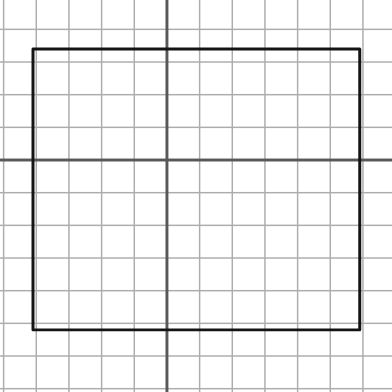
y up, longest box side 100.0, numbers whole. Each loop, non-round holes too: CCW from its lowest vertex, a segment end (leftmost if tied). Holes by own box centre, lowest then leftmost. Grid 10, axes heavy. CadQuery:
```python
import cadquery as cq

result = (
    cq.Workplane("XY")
    .moveTo(-41.0, -52.0)
    .lineTo(59.0, -52.0)
    .lineTo(59.0, 34.0)
    .lineTo(-41.0, 34.0)
    .close()
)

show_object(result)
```